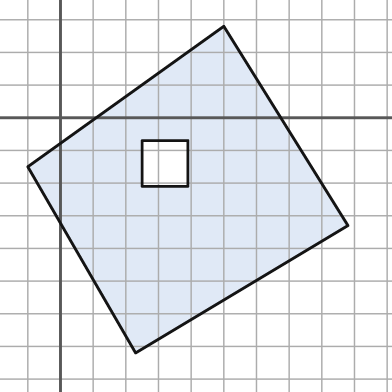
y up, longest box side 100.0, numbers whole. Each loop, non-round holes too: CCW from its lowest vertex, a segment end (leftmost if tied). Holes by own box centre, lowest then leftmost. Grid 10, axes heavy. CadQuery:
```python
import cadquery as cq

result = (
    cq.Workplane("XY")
    .moveTo(23.0, -72.0)
    .lineTo(88.0, -33.0)
    .lineTo(50.0, 28.0)
    .lineTo(-10.0, -15.0)
    .close()
    .moveTo(25.0, -21.0)
    .lineTo(39.0, -21.0)
    .lineTo(39.0, -7.0)
    .lineTo(25.0, -7.0)
    .close()
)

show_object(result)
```